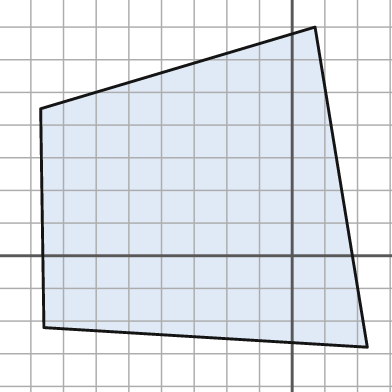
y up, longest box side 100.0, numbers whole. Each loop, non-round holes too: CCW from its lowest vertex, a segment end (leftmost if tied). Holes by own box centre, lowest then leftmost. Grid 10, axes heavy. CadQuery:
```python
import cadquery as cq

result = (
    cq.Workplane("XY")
    .moveTo(23.0, -28.0)
    .lineTo(7.0, 70.0)
    .lineTo(-77.0, 45.0)
    .lineTo(-76.0, -22.0)
    .close()
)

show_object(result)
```